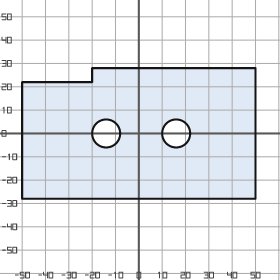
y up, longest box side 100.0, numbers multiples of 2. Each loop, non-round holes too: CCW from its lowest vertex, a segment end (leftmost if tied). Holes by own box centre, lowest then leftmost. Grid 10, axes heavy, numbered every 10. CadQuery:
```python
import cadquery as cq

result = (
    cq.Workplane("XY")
    .moveTo(-50.0, -28.0)
    .lineTo(50.0, -28.0)
    .lineTo(50.0, 28.0)
    .lineTo(-20.0, 28.0)
    .lineTo(-20.0, 22.0)
    .lineTo(-50.0, 22.0)
    .close()
    .moveTo(-14.0, 0.0)
    .circle(6.0)
    .moveTo(16.0, 0.0)
    .circle(6.0)
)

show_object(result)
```